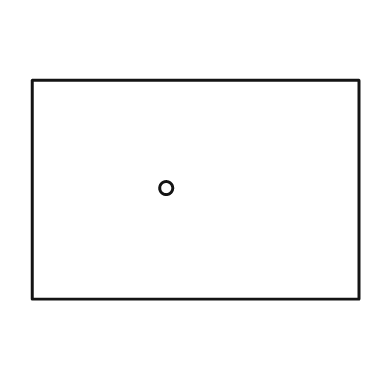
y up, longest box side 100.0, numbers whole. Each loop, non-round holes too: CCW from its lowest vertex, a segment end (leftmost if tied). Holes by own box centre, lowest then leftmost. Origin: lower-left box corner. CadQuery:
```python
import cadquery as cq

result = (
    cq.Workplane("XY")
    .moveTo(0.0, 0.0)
    .lineTo(100.0, 0.0)
    .lineTo(100.0, 67.0)
    .lineTo(0.0, 67.0)
    .close()
    .moveTo(41.0, 34.0)
    .circle(2.0)
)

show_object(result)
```